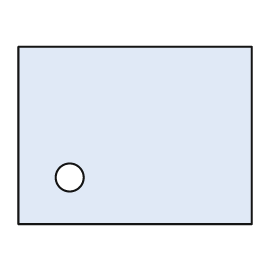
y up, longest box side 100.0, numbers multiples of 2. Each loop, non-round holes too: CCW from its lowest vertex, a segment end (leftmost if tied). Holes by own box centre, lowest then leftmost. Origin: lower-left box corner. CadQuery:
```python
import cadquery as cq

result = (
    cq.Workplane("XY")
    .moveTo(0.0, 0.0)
    .lineTo(100.0, 0.0)
    .lineTo(100.0, 76.0)
    .lineTo(0.0, 76.0)
    .close()
    .moveTo(22.0, 20.0)
    .circle(6.0)
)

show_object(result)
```